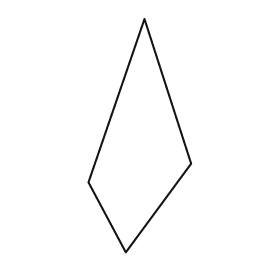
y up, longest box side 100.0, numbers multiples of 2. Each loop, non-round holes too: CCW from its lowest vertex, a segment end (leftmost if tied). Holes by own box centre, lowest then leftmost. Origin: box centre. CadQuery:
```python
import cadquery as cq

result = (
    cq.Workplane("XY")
    .moveTo(-6.0, -50.0)
    .lineTo(22.0, -12.0)
    .lineTo(2.0, 50.0)
    .lineTo(-22.0, -20.0)
    .close()
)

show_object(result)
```